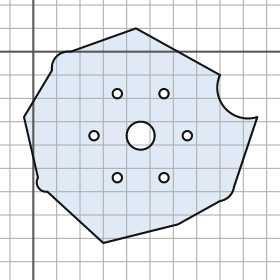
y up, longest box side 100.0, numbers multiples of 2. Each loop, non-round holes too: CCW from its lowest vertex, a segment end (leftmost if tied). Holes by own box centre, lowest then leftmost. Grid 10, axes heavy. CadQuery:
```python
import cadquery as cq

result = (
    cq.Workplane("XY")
    .moveTo(30.0, -82.0)
    .lineTo(62.0, -74.0)
    .lineTo(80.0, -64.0)
    .threePointArc((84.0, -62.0), (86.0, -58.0))
    .lineTo(96.0, -28.0)
    .threePointArc((82.0, -24.0), (80.0, -10.0))
    .lineTo(44.0, 10.0)
    .lineTo(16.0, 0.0)
    .threePointArc((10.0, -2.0), (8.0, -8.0))
    .lineTo(-4.0, -28.0)
    .lineTo(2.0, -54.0)
    .threePointArc((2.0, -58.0), (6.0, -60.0))
    .close()
    .moveTo(36.0, -54.0)
    .circle(2.0)
    .moveTo(56.0, -54.0)
    .circle(2.0)
    .moveTo(26.0, -36.0)
    .circle(2.0)
    .moveTo(46.0, -36.0)
    .circle(6.0)
    .moveTo(66.0, -36.0)
    .circle(2.0)
    .moveTo(36.0, -18.0)
    .circle(2.0)
    .moveTo(56.0, -18.0)
    .circle(2.0)
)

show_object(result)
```